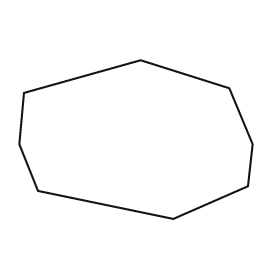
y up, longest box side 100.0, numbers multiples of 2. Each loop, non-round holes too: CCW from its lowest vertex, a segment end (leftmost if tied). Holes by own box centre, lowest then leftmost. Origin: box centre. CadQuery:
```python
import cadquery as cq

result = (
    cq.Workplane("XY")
    .moveTo(16.0, -34.0)
    .lineTo(48.0, -20.0)
    .lineTo(50.0, -2.0)
    .lineTo(40.0, 22.0)
    .lineTo(2.0, 34.0)
    .lineTo(-48.0, 20.0)
    .lineTo(-50.0, -2.0)
    .lineTo(-42.0, -22.0)
    .close()
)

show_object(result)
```